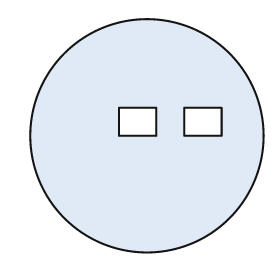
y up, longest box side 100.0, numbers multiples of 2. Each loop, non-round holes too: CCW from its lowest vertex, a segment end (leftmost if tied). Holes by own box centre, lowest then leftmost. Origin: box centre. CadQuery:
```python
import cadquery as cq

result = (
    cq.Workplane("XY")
    .moveTo(0.0, 0.0)
    .circle(50.0)
    .moveTo(-12.0, 0.0)
    .lineTo(4.0, 0.0)
    .lineTo(4.0, 12.0)
    .lineTo(-12.0, 12.0)
    .close()
    .moveTo(16.0, 0.0)
    .lineTo(32.0, 0.0)
    .lineTo(32.0, 12.0)
    .lineTo(16.0, 12.0)
    .close()
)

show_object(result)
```